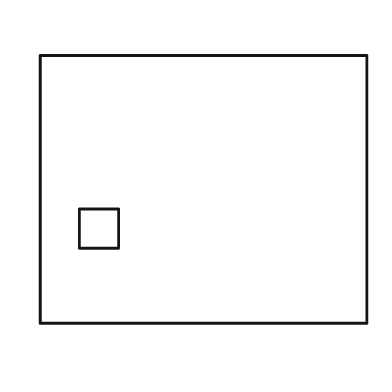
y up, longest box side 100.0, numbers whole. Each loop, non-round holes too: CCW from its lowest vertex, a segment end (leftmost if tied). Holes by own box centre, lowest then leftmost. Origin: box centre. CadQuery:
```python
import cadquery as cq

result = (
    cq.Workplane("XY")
    .moveTo(-50.0, -41.0)
    .lineTo(50.0, -41.0)
    .lineTo(50.0, 41.0)
    .lineTo(-50.0, 41.0)
    .close()
    .moveTo(-38.0, -18.0)
    .lineTo(-26.0, -18.0)
    .lineTo(-26.0, -6.0)
    .lineTo(-38.0, -6.0)
    .close()
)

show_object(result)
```